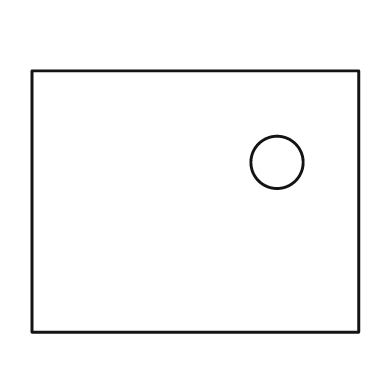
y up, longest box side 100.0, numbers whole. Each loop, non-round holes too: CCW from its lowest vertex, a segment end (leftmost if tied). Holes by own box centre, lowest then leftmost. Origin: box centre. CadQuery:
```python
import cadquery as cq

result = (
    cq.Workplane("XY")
    .moveTo(-50.0, -40.0)
    .lineTo(50.0, -40.0)
    .lineTo(50.0, 40.0)
    .lineTo(-50.0, 40.0)
    .close()
    .moveTo(25.0, 12.0)
    .circle(8.0)
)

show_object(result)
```